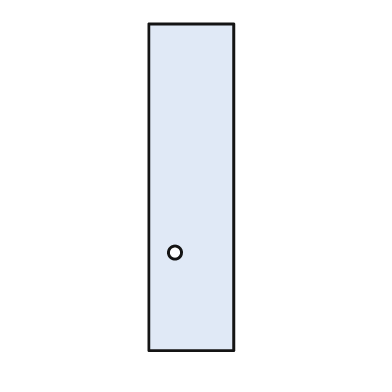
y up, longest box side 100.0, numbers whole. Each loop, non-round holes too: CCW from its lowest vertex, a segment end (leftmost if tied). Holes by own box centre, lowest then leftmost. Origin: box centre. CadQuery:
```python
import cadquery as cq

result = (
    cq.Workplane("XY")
    .moveTo(-13.0, -50.0)
    .lineTo(13.0, -50.0)
    .lineTo(13.0, 50.0)
    .lineTo(-13.0, 50.0)
    .close()
    .moveTo(-5.0, -20.0)
    .circle(2.0)
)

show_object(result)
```